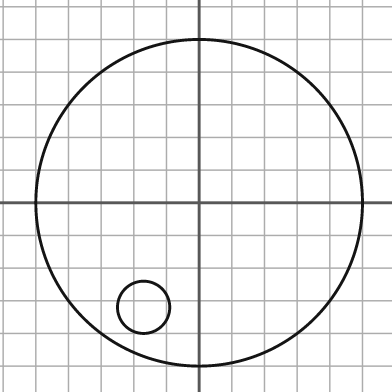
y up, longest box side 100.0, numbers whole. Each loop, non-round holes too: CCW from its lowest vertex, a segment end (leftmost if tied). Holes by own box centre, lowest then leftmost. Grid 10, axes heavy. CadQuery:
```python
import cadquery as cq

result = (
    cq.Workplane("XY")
    .moveTo(0.0, 0.0)
    .circle(50.0)
    .moveTo(-17.0, -32.0)
    .circle(8.0)
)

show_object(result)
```